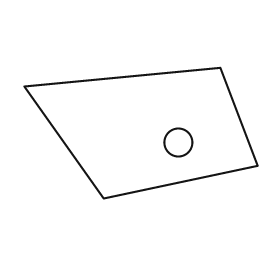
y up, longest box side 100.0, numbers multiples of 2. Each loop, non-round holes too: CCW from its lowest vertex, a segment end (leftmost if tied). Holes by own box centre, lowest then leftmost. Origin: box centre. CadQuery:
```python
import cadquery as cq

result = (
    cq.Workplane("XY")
    .moveTo(-16.0, -28.0)
    .lineTo(50.0, -14.0)
    .lineTo(34.0, 28.0)
    .lineTo(-50.0, 20.0)
    .close()
    .moveTo(16.0, -4.0)
    .circle(6.0)
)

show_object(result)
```